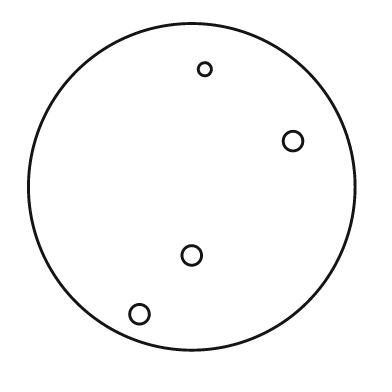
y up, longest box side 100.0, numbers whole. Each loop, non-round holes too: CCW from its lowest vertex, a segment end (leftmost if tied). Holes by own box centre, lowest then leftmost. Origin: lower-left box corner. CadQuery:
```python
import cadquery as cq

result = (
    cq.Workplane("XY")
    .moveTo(50.0, 50.0)
    .circle(50.0)
    .moveTo(34.0, 11.0)
    .circle(3.0)
    .moveTo(50.0, 29.0)
    .circle(3.0)
    .moveTo(81.0, 64.0)
    .circle(3.0)
    .moveTo(54.0, 86.0)
    .circle(2.0)
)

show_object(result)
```